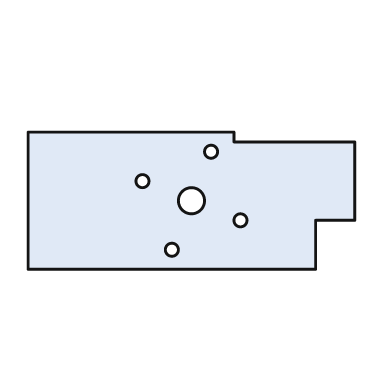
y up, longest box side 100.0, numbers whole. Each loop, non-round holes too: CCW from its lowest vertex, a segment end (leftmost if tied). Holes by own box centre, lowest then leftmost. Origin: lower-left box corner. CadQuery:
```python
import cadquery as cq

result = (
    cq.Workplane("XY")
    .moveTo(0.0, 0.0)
    .lineTo(88.0, 0.0)
    .lineTo(88.0, 15.0)
    .lineTo(100.0, 15.0)
    .lineTo(100.0, 39.0)
    .lineTo(63.0, 39.0)
    .lineTo(63.0, 42.0)
    .lineTo(0.0, 42.0)
    .close()
    .moveTo(44.0, 6.0)
    .circle(2.0)
    .moveTo(65.0, 15.0)
    .circle(2.0)
    .moveTo(50.0, 21.0)
    .circle(4.0)
    .moveTo(35.0, 27.0)
    .circle(2.0)
    .moveTo(56.0, 36.0)
    .circle(2.0)
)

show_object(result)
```